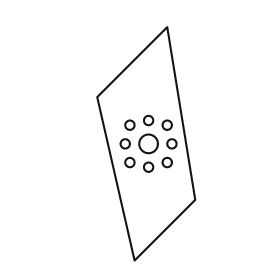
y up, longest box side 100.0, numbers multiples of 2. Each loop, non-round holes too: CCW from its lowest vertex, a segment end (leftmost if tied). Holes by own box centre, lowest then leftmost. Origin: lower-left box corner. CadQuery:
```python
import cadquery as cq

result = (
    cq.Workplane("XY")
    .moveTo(16.0, 0.0)
    .lineTo(42.0, 26.0)
    .lineTo(30.0, 100.0)
    .lineTo(0.0, 70.0)
    .close()
    .moveTo(22.0, 40.0)
    .circle(2.0)
    .moveTo(14.0, 42.0)
    .circle(2.0)
    .moveTo(30.0, 42.0)
    .circle(2.0)
    .moveTo(12.0, 50.0)
    .circle(2.0)
    .moveTo(22.0, 50.0)
    .circle(4.0)
    .moveTo(32.0, 50.0)
    .circle(2.0)
    .moveTo(14.0, 58.0)
    .circle(2.0)
    .moveTo(30.0, 58.0)
    .circle(2.0)
    .moveTo(22.0, 60.0)
    .circle(2.0)
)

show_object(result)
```